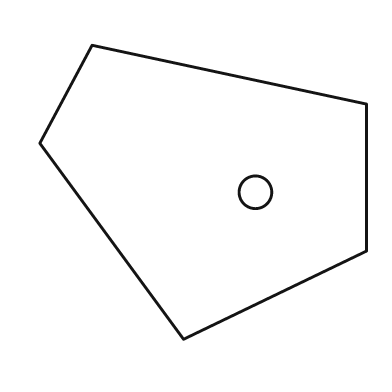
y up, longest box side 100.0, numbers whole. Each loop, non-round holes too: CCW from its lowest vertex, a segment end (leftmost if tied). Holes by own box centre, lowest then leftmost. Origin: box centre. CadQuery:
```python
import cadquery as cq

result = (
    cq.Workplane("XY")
    .moveTo(-6.0, -45.0)
    .lineTo(50.0, -18.0)
    .lineTo(50.0, 27.0)
    .lineTo(-34.0, 45.0)
    .lineTo(-50.0, 15.0)
    .close()
    .moveTo(16.0, 0.0)
    .circle(5.0)
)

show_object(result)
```